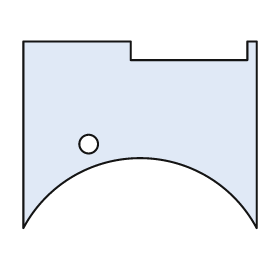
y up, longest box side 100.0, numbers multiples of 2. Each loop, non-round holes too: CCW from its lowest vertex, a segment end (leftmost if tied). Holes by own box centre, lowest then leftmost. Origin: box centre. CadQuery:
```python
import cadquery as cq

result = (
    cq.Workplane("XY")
    .moveTo(-50.0, -40.0)
    .threePointArc((0.0, -10.0), (50.0, -40.0))
    .lineTo(50.0, 40.0)
    .lineTo(46.0, 40.0)
    .lineTo(46.0, 32.0)
    .lineTo(-4.0, 32.0)
    .lineTo(-4.0, 40.0)
    .lineTo(-50.0, 40.0)
    .close()
    .moveTo(-22.0, -4.0)
    .circle(4.0)
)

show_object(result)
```